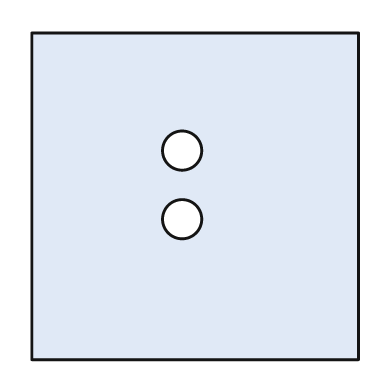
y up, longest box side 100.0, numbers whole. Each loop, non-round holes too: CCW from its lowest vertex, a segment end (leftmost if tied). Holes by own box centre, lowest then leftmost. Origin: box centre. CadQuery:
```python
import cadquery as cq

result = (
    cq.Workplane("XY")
    .moveTo(-50.0, -50.0)
    .lineTo(50.0, -50.0)
    .lineTo(50.0, 50.0)
    .lineTo(-50.0, 50.0)
    .close()
    .moveTo(-4.0, -7.0)
    .circle(6.0)
    .moveTo(-4.0, 14.0)
    .circle(6.0)
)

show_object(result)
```